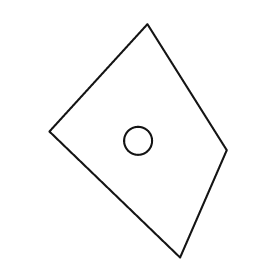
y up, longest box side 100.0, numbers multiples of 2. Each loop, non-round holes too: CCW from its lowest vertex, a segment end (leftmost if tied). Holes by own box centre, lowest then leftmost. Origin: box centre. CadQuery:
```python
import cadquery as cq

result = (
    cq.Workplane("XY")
    .moveTo(18.0, -50.0)
    .lineTo(38.0, -4.0)
    .lineTo(4.0, 50.0)
    .lineTo(-38.0, 4.0)
    .close()
    .moveTo(0.0, 0.0)
    .circle(6.0)
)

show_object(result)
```